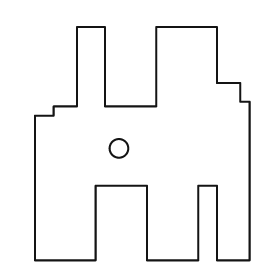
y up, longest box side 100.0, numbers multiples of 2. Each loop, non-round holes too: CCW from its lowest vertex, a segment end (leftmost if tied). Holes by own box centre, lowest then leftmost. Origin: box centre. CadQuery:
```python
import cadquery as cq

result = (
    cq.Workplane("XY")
    .moveTo(-46.0, -50.0)
    .lineTo(-20.0, -50.0)
    .lineTo(-20.0, -18.0)
    .lineTo(2.0, -18.0)
    .lineTo(2.0, -50.0)
    .lineTo(24.0, -50.0)
    .lineTo(24.0, -18.0)
    .lineTo(32.0, -18.0)
    .lineTo(32.0, -50.0)
    .lineTo(46.0, -50.0)
    .lineTo(46.0, 18.0)
    .lineTo(42.0, 18.0)
    .lineTo(42.0, 26.0)
    .lineTo(32.0, 26.0)
    .lineTo(32.0, 50.0)
    .lineTo(6.0, 50.0)
    .lineTo(6.0, 16.0)
    .lineTo(-16.0, 16.0)
    .lineTo(-16.0, 50.0)
    .lineTo(-28.0, 50.0)
    .lineTo(-28.0, 16.0)
    .lineTo(-38.0, 16.0)
    .lineTo(-38.0, 12.0)
    .lineTo(-46.0, 12.0)
    .close()
    .moveTo(-10.0, -2.0)
    .circle(4.0)
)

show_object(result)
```